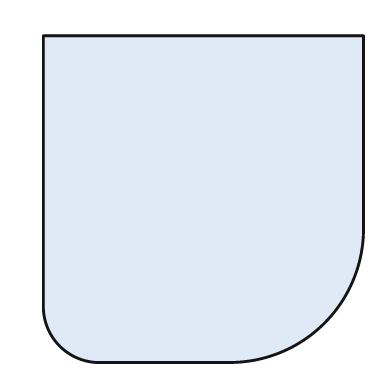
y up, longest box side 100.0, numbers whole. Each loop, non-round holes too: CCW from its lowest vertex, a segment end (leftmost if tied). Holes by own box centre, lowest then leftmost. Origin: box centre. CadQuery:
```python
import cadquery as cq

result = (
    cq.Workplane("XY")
    .moveTo(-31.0, -50.0)
    .lineTo(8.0, -50.0)
    .threePointArc((37.0, -38.0), (49.0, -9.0))
    .lineTo(49.0, 50.0)
    .lineTo(-49.0, 50.0)
    .lineTo(-49.0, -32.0)
    .threePointArc((-44.0, -45.0), (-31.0, -50.0))
    .close()
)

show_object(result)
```